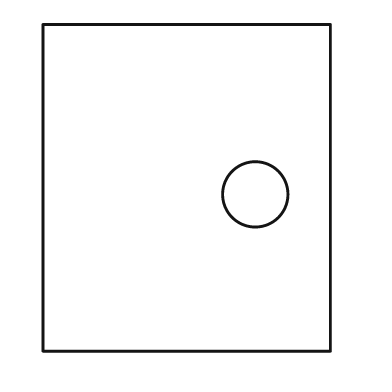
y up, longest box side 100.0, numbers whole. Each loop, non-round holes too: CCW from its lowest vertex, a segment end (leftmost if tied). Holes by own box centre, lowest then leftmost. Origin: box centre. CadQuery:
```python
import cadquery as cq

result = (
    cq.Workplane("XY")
    .moveTo(-44.0, -50.0)
    .lineTo(44.0, -50.0)
    .lineTo(44.0, 50.0)
    .lineTo(-44.0, 50.0)
    .close()
    .moveTo(21.0, -2.0)
    .circle(10.0)
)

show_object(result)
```